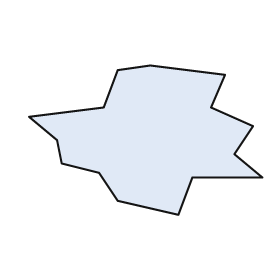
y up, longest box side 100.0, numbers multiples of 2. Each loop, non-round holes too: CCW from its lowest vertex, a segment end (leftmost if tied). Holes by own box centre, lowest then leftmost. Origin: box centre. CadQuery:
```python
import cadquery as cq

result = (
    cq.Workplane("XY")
    .moveTo(14.0, -32.0)
    .lineTo(20.0, -16.0)
    .lineTo(50.0, -16.0)
    .lineTo(38.0, -6.0)
    .lineTo(46.0, 6.0)
    .lineTo(28.0, 14.0)
    .lineTo(34.0, 28.0)
    .lineTo(2.0, 32.0)
    .lineTo(-12.0, 30.0)
    .lineTo(-18.0, 14.0)
    .lineTo(-50.0, 10.0)
    .lineTo(-38.0, 0.0)
    .lineTo(-36.0, -10.0)
    .lineTo(-20.0, -14.0)
    .lineTo(-12.0, -26.0)
    .close()
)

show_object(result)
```